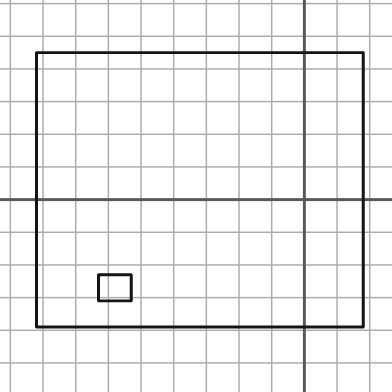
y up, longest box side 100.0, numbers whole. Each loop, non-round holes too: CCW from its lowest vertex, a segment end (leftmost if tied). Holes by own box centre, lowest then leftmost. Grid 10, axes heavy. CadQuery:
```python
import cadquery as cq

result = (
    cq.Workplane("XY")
    .moveTo(-82.0, -39.0)
    .lineTo(18.0, -39.0)
    .lineTo(18.0, 45.0)
    .lineTo(-82.0, 45.0)
    .close()
    .moveTo(-63.0, -31.0)
    .lineTo(-53.0, -31.0)
    .lineTo(-53.0, -23.0)
    .lineTo(-63.0, -23.0)
    .close()
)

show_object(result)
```